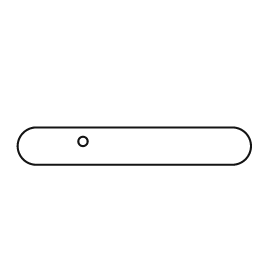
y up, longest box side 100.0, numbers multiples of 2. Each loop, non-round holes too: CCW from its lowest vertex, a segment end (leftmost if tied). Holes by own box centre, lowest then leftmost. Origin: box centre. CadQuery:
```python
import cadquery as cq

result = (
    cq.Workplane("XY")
    .moveTo(-42.0, -8.0)
    .lineTo(42.0, -8.0)
    .threePointArc((50.0, 0.0), (42.0, 8.0))
    .lineTo(-42.0, 8.0)
    .threePointArc((-50.0, 0.0), (-42.0, -8.0))
    .close()
    .moveTo(-22.0, 2.0)
    .circle(2.0)
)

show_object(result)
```